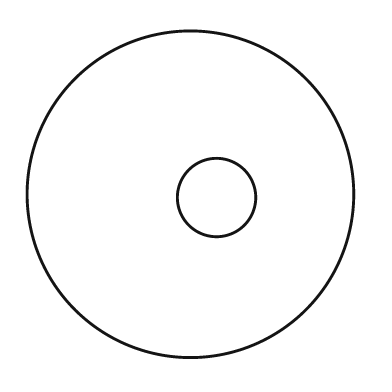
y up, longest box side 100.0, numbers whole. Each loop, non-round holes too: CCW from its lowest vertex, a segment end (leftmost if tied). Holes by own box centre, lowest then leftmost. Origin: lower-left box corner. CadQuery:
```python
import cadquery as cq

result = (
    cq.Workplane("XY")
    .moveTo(50.0, 50.0)
    .circle(50.0)
    .moveTo(58.0, 49.0)
    .circle(12.0)
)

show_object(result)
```